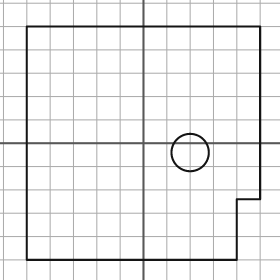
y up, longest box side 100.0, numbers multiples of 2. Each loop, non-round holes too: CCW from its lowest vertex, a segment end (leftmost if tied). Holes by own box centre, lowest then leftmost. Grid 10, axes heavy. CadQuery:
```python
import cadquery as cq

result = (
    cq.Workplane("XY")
    .moveTo(-50.0, -50.0)
    .lineTo(40.0, -50.0)
    .lineTo(40.0, -24.0)
    .lineTo(50.0, -24.0)
    .lineTo(50.0, 50.0)
    .lineTo(-50.0, 50.0)
    .close()
    .moveTo(20.0, -4.0)
    .circle(8.0)
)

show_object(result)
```